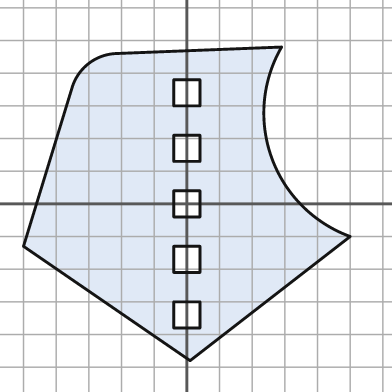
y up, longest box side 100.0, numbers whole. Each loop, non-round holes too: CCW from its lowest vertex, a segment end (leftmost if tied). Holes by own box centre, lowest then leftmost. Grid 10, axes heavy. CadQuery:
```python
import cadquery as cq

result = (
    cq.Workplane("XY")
    .moveTo(1.0, -48.0)
    .lineTo(50.0, -10.0)
    .threePointArc((26.0, 14.0), (29.0, 48.0))
    .lineTo(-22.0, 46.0)
    .threePointArc((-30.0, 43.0), (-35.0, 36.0))
    .lineTo(-50.0, -13.0)
    .close()
    .moveTo(-4.0, -38.0)
    .lineTo(4.0, -38.0)
    .lineTo(4.0, -30.0)
    .lineTo(-4.0, -30.0)
    .close()
    .moveTo(-4.0, -21.0)
    .lineTo(4.0, -21.0)
    .lineTo(4.0, -13.0)
    .lineTo(-4.0, -13.0)
    .close()
    .moveTo(-4.0, -4.0)
    .lineTo(4.0, -4.0)
    .lineTo(4.0, 4.0)
    .lineTo(-4.0, 4.0)
    .close()
    .moveTo(-4.0, 13.0)
    .lineTo(4.0, 13.0)
    .lineTo(4.0, 21.0)
    .lineTo(-4.0, 21.0)
    .close()
    .moveTo(-4.0, 30.0)
    .lineTo(4.0, 30.0)
    .lineTo(4.0, 38.0)
    .lineTo(-4.0, 38.0)
    .close()
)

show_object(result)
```